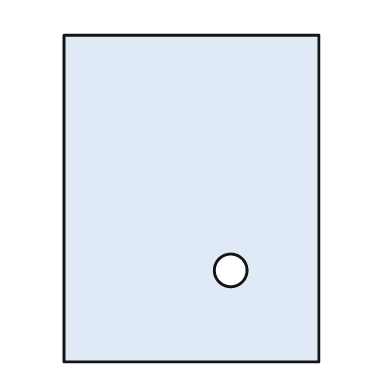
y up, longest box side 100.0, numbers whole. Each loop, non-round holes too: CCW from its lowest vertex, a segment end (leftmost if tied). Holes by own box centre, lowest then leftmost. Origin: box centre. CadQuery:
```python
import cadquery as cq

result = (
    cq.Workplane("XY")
    .moveTo(-39.0, -50.0)
    .lineTo(39.0, -50.0)
    .lineTo(39.0, 50.0)
    .lineTo(-39.0, 50.0)
    .close()
    .moveTo(12.0, -22.0)
    .circle(5.0)
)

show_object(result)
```